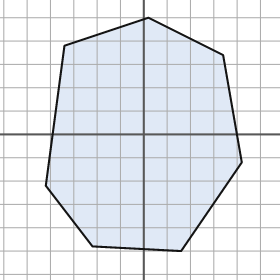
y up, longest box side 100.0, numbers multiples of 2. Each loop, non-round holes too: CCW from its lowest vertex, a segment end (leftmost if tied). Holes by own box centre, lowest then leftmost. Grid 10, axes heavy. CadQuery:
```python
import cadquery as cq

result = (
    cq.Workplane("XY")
    .moveTo(16.0, -50.0)
    .lineTo(42.0, -12.0)
    .lineTo(34.0, 34.0)
    .lineTo(2.0, 50.0)
    .lineTo(-34.0, 38.0)
    .lineTo(-42.0, -22.0)
    .lineTo(-22.0, -48.0)
    .close()
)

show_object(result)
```